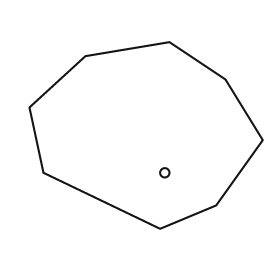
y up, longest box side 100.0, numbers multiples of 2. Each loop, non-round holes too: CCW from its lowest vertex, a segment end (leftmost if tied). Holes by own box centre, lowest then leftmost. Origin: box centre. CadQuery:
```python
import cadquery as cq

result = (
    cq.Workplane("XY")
    .moveTo(6.0, -40.0)
    .lineTo(30.0, -30.0)
    .lineTo(50.0, -2.0)
    .lineTo(34.0, 24.0)
    .lineTo(10.0, 40.0)
    .lineTo(-26.0, 34.0)
    .lineTo(-50.0, 12.0)
    .lineTo(-44.0, -16.0)
    .close()
    .moveTo(8.0, -16.0)
    .circle(2.0)
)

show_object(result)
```